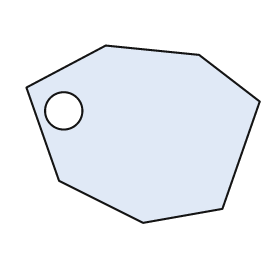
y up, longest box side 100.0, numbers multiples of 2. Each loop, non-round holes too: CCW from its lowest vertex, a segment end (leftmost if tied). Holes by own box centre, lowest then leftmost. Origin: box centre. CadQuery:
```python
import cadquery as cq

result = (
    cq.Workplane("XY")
    .moveTo(0.0, -38.0)
    .lineTo(34.0, -32.0)
    .lineTo(50.0, 14.0)
    .lineTo(24.0, 34.0)
    .lineTo(-16.0, 38.0)
    .lineTo(-50.0, 20.0)
    .lineTo(-36.0, -20.0)
    .close()
    .moveTo(-34.0, 10.0)
    .circle(8.0)
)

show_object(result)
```